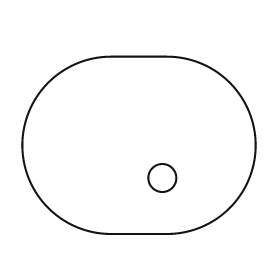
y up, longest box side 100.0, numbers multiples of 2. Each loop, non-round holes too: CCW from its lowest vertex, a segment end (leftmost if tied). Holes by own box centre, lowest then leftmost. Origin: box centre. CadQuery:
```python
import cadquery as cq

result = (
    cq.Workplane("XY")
    .moveTo(-12.0, -38.0)
    .lineTo(12.0, -38.0)
    .threePointArc((50.0, 0.0), (12.0, 38.0))
    .lineTo(-12.0, 38.0)
    .threePointArc((-50.0, 0.0), (-12.0, -38.0))
    .close()
    .moveTo(10.0, -14.0)
    .circle(6.0)
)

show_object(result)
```